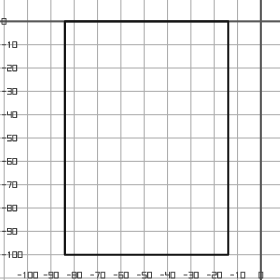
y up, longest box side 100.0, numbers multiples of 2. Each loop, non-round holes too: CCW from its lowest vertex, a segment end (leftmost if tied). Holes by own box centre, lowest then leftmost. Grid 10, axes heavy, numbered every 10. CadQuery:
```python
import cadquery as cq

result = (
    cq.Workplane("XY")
    .moveTo(-84.0, -100.0)
    .lineTo(-14.0, -100.0)
    .lineTo(-14.0, 0.0)
    .lineTo(-84.0, 0.0)
    .close()
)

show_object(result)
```